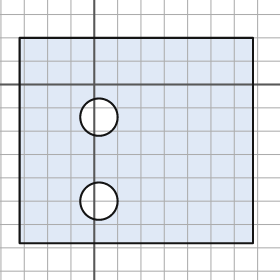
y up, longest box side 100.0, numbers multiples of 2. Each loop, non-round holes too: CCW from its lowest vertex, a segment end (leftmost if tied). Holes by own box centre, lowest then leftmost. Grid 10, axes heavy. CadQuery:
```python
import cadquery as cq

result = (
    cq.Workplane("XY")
    .moveTo(-32.0, -68.0)
    .lineTo(68.0, -68.0)
    .lineTo(68.0, 20.0)
    .lineTo(-32.0, 20.0)
    .close()
    .moveTo(2.0, -50.0)
    .circle(8.0)
    .moveTo(2.0, -14.0)
    .circle(8.0)
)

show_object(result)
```